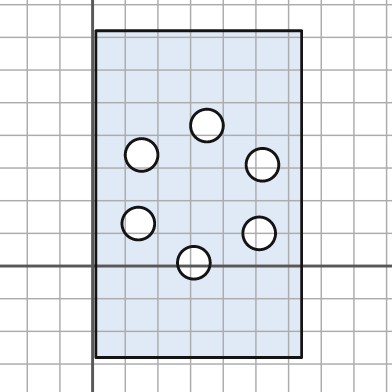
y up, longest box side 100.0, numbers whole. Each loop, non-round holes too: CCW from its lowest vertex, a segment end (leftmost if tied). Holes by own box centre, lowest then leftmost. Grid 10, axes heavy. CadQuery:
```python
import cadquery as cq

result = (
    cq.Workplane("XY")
    .moveTo(1.0, -28.0)
    .lineTo(64.0, -28.0)
    .lineTo(64.0, 72.0)
    .lineTo(1.0, 72.0)
    .close()
    .moveTo(31.0, 1.0)
    .circle(5.0)
    .moveTo(51.0, 10.0)
    .circle(5.0)
    .moveTo(14.0, 13.0)
    .circle(5.0)
    .moveTo(52.0, 31.0)
    .circle(5.0)
    .moveTo(15.0, 34.0)
    .circle(5.0)
    .moveTo(35.0, 43.0)
    .circle(5.0)
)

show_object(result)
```